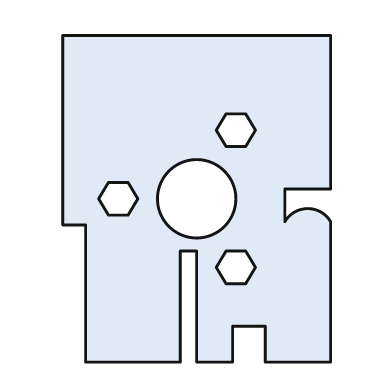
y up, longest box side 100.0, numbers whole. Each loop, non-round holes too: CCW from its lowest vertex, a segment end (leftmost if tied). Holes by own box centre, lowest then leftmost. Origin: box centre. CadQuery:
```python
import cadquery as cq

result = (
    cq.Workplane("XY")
    .moveTo(-34.0, -50.0)
    .lineTo(-5.0, -50.0)
    .lineTo(-5.0, -16.0)
    .lineTo(0.0, -16.0)
    .lineTo(0.0, -50.0)
    .lineTo(11.0, -50.0)
    .lineTo(11.0, -39.0)
    .lineTo(21.0, -39.0)
    .lineTo(21.0, -50.0)
    .lineTo(41.0, -50.0)
    .lineTo(41.0, -7.0)
    .threePointArc((34.0, -3.0), (27.0, -7.0))
    .lineTo(27.0, 3.0)
    .lineTo(41.0, 3.0)
    .lineTo(41.0, 50.0)
    .lineTo(-41.0, 50.0)
    .lineTo(-41.0, -8.0)
    .lineTo(-34.0, -8.0)
    .close()
    .moveTo(9.0, -26.0)
    .lineTo(15.0, -26.0)
    .lineTo(18.0, -21.0)
    .lineTo(15.0, -16.0)
    .lineTo(9.0, -16.0)
    .lineTo(6.0, -21.0)
    .close()
    .moveTo(-27.0, -5.0)
    .lineTo(-21.0, -5.0)
    .lineTo(-18.0, 0.0)
    .lineTo(-21.0, 5.0)
    .lineTo(-27.0, 5.0)
    .lineTo(-30.0, 0.0)
    .close()
    .moveTo(0.0, 0.0)
    .circle(12.0)
    .moveTo(9.0, 16.0)
    .lineTo(15.0, 16.0)
    .lineTo(18.0, 21.0)
    .lineTo(15.0, 26.0)
    .lineTo(9.0, 26.0)
    .lineTo(6.0, 21.0)
    .close()
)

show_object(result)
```